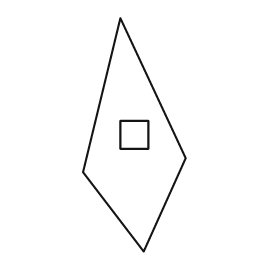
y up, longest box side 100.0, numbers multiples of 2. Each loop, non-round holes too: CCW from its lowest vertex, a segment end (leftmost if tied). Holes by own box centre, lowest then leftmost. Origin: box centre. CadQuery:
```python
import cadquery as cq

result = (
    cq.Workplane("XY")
    .moveTo(4.0, -50.0)
    .lineTo(22.0, -10.0)
    .lineTo(-6.0, 50.0)
    .lineTo(-22.0, -16.0)
    .close()
    .moveTo(-6.0, -6.0)
    .lineTo(6.0, -6.0)
    .lineTo(6.0, 6.0)
    .lineTo(-6.0, 6.0)
    .close()
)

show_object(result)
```